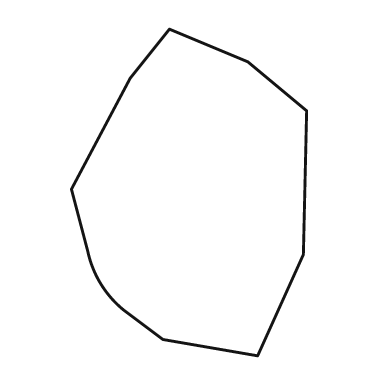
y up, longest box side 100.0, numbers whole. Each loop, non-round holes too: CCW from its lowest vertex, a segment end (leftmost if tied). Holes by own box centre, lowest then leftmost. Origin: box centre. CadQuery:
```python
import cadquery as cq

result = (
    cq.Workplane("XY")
    .moveTo(21.0, -50.0)
    .lineTo(35.0, -19.0)
    .lineTo(36.0, 25.0)
    .lineTo(18.0, 40.0)
    .lineTo(-6.0, 50.0)
    .lineTo(-18.0, 35.0)
    .lineTo(-36.0, 1.0)
    .lineTo(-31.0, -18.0)
    .threePointArc((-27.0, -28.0), (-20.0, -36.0))
    .lineTo(-8.0, -45.0)
    .close()
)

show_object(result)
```